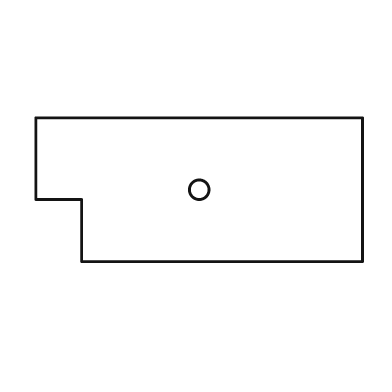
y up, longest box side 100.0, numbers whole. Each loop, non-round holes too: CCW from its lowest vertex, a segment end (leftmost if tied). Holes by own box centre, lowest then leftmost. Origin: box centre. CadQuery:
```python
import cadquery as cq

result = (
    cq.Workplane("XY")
    .moveTo(-36.0, -22.0)
    .lineTo(50.0, -22.0)
    .lineTo(50.0, 22.0)
    .lineTo(-50.0, 22.0)
    .lineTo(-50.0, -3.0)
    .lineTo(-36.0, -3.0)
    .close()
    .moveTo(0.0, 0.0)
    .circle(3.0)
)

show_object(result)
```